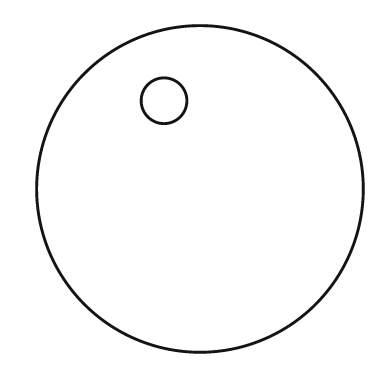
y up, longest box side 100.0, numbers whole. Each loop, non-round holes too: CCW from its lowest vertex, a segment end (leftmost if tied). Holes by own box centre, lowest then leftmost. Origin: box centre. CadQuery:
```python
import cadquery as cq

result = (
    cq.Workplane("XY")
    .moveTo(0.0, 0.0)
    .circle(50.0)
    .moveTo(-11.0, 27.0)
    .circle(7.0)
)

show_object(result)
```